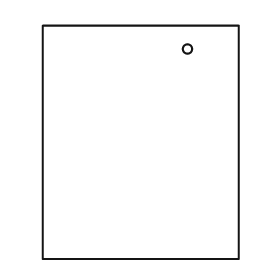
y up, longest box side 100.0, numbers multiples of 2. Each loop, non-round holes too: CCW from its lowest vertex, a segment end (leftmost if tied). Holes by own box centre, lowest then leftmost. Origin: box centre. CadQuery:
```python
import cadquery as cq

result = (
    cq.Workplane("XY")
    .moveTo(-42.0, -50.0)
    .lineTo(42.0, -50.0)
    .lineTo(42.0, 50.0)
    .lineTo(-42.0, 50.0)
    .close()
    .moveTo(20.0, 40.0)
    .circle(2.0)
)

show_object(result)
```